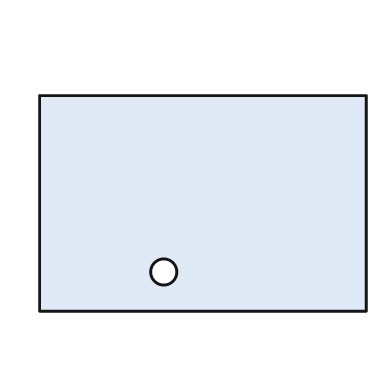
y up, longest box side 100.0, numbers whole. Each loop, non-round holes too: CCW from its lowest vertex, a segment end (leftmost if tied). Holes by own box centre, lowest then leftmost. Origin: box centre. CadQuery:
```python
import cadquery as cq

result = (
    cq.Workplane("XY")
    .moveTo(-50.0, -33.0)
    .lineTo(50.0, -33.0)
    .lineTo(50.0, 33.0)
    .lineTo(-50.0, 33.0)
    .close()
    .moveTo(-12.0, -21.0)
    .circle(4.0)
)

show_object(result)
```